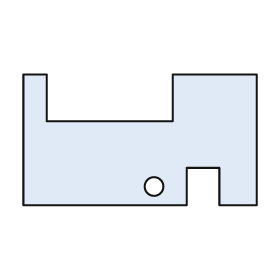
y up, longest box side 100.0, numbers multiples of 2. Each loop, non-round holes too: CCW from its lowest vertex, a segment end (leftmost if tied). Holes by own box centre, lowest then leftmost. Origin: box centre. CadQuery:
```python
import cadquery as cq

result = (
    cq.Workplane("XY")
    .moveTo(-50.0, -28.0)
    .lineTo(20.0, -28.0)
    .lineTo(20.0, -12.0)
    .lineTo(34.0, -12.0)
    .lineTo(34.0, -28.0)
    .lineTo(50.0, -28.0)
    .lineTo(50.0, 28.0)
    .lineTo(14.0, 28.0)
    .lineTo(14.0, 8.0)
    .lineTo(-40.0, 8.0)
    .lineTo(-40.0, 28.0)
    .lineTo(-50.0, 28.0)
    .close()
    .moveTo(6.0, -20.0)
    .circle(4.0)
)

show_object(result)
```